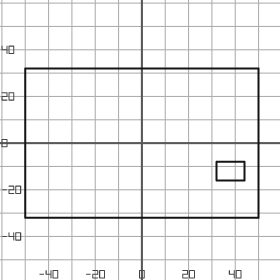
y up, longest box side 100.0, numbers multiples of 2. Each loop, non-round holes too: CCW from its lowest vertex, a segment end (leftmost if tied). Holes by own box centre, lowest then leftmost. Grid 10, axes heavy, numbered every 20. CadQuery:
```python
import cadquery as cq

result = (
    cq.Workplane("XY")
    .moveTo(-50.0, -32.0)
    .lineTo(50.0, -32.0)
    .lineTo(50.0, 32.0)
    .lineTo(-50.0, 32.0)
    .close()
    .moveTo(32.0, -16.0)
    .lineTo(44.0, -16.0)
    .lineTo(44.0, -8.0)
    .lineTo(32.0, -8.0)
    .close()
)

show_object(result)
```